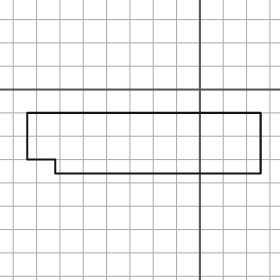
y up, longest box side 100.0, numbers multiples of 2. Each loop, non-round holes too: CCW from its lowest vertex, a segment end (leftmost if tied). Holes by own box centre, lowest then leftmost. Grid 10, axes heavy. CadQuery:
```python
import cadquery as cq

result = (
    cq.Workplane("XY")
    .moveTo(-62.0, -36.0)
    .lineTo(26.0, -36.0)
    .lineTo(26.0, -10.0)
    .lineTo(-74.0, -10.0)
    .lineTo(-74.0, -30.0)
    .lineTo(-62.0, -30.0)
    .close()
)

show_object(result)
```